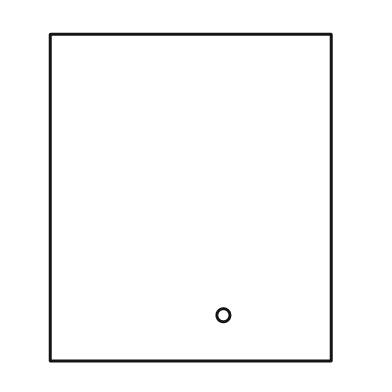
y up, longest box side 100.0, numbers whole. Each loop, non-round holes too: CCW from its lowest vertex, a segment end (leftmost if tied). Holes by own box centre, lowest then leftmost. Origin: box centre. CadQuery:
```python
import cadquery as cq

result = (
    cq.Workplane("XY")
    .moveTo(-43.0, -50.0)
    .lineTo(43.0, -50.0)
    .lineTo(43.0, 50.0)
    .lineTo(-43.0, 50.0)
    .close()
    .moveTo(10.0, -36.0)
    .circle(2.0)
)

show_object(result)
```